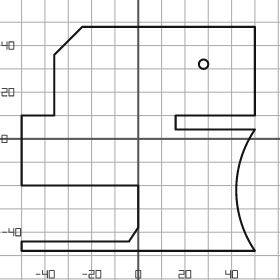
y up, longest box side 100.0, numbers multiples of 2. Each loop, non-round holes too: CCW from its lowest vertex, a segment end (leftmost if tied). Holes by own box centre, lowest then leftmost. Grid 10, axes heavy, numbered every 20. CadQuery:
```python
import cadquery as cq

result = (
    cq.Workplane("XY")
    .moveTo(-50.0, -48.0)
    .lineTo(50.0, -48.0)
    .threePointArc((42.0, -22.0), (50.0, 4.0))
    .lineTo(16.0, 4.0)
    .lineTo(16.0, 10.0)
    .lineTo(50.0, 10.0)
    .lineTo(50.0, 48.0)
    .lineTo(-24.0, 48.0)
    .lineTo(-36.0, 36.0)
    .lineTo(-36.0, 10.0)
    .lineTo(-50.0, 10.0)
    .lineTo(-50.0, -20.0)
    .lineTo(0.0, -20.0)
    .lineTo(0.0, -38.0)
    .lineTo(-4.0, -44.0)
    .lineTo(-50.0, -44.0)
    .close()
    .moveTo(28.0, 32.0)
    .circle(2.0)
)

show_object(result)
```